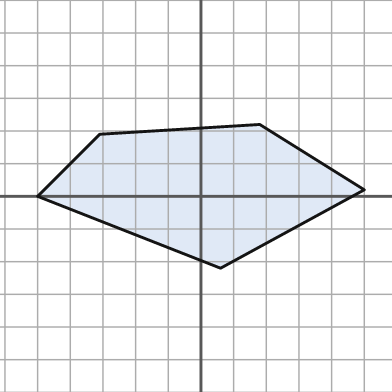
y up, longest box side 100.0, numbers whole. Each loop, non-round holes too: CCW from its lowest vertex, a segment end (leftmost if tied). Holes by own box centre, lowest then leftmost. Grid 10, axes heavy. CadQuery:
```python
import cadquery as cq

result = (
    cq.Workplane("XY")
    .moveTo(6.0, -22.0)
    .lineTo(50.0, 2.0)
    .lineTo(18.0, 22.0)
    .lineTo(-31.0, 19.0)
    .lineTo(-50.0, 0.0)
    .close()
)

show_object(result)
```